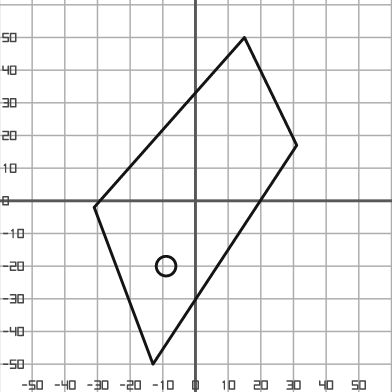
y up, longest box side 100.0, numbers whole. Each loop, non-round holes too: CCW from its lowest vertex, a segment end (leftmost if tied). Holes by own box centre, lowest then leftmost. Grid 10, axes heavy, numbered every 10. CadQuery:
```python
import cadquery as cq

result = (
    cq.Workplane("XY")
    .moveTo(-13.0, -50.0)
    .lineTo(31.0, 17.0)
    .lineTo(15.0, 50.0)
    .lineTo(-31.0, -2.0)
    .close()
    .moveTo(-9.0, -20.0)
    .circle(3.0)
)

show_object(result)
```